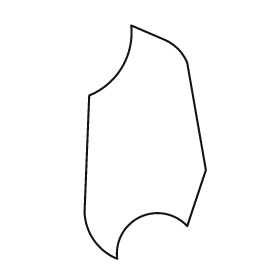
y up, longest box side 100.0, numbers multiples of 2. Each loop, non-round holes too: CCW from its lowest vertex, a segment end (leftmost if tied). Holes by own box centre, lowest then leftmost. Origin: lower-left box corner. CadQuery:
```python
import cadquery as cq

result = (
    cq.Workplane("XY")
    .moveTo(14.0, 0.0)
    .threePointArc((24.0, 18.0), (44.0, 14.0))
    .lineTo(52.0, 38.0)
    .lineTo(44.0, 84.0)
    .threePointArc((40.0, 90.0), (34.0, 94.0))
    .lineTo(20.0, 100.0)
    .threePointArc((16.0, 82.0), (2.0, 70.0))
    .lineTo(0.0, 20.0)
    .threePointArc((4.0, 8.0), (14.0, 0.0))
    .close()
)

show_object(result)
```